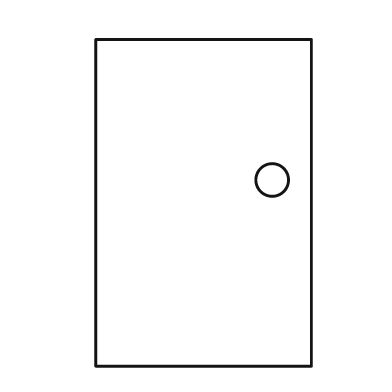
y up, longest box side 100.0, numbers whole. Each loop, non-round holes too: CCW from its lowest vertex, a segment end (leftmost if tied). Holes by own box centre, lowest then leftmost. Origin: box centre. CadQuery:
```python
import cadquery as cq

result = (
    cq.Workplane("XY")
    .moveTo(-33.0, -50.0)
    .lineTo(33.0, -50.0)
    .lineTo(33.0, 50.0)
    .lineTo(-33.0, 50.0)
    .close()
    .moveTo(21.0, 7.0)
    .circle(5.0)
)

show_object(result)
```